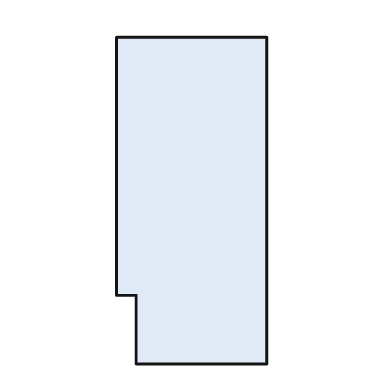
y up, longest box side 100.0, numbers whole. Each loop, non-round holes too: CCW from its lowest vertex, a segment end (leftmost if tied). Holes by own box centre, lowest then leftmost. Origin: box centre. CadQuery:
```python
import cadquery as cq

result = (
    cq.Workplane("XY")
    .moveTo(-17.0, -50.0)
    .lineTo(23.0, -50.0)
    .lineTo(23.0, 50.0)
    .lineTo(-23.0, 50.0)
    .lineTo(-23.0, -29.0)
    .lineTo(-17.0, -29.0)
    .close()
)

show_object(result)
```